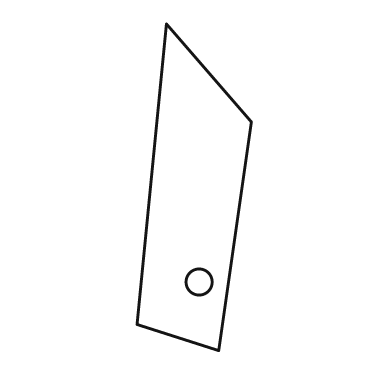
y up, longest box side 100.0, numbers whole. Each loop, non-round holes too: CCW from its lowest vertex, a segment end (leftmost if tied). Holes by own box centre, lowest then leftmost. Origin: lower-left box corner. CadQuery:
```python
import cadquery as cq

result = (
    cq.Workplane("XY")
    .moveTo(25.0, 0.0)
    .lineTo(35.0, 70.0)
    .lineTo(9.0, 100.0)
    .lineTo(0.0, 8.0)
    .close()
    .moveTo(19.0, 21.0)
    .circle(4.0)
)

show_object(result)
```